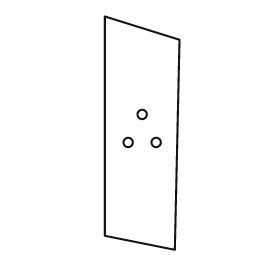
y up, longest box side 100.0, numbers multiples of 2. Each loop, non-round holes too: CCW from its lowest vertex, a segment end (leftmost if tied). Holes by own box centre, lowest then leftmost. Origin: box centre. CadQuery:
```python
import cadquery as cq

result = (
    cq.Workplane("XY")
    .moveTo(14.0, -50.0)
    .lineTo(16.0, 40.0)
    .lineTo(-16.0, 50.0)
    .lineTo(-16.0, -44.0)
    .close()
    .moveTo(-6.0, -4.0)
    .circle(2.0)
    .moveTo(6.0, -4.0)
    .circle(2.0)
    .moveTo(0.0, 8.0)
    .circle(2.0)
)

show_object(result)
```